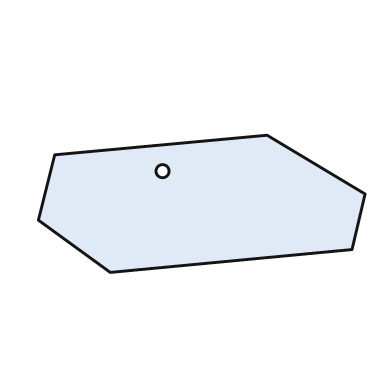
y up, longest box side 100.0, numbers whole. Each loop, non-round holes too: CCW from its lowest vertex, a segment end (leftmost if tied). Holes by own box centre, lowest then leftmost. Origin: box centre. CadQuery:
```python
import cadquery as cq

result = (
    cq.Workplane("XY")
    .moveTo(-28.0, -21.0)
    .lineTo(46.0, -14.0)
    .lineTo(50.0, 3.0)
    .lineTo(20.0, 21.0)
    .lineTo(-45.0, 15.0)
    .lineTo(-50.0, -5.0)
    .close()
    .moveTo(-12.0, 10.0)
    .circle(2.0)
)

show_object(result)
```